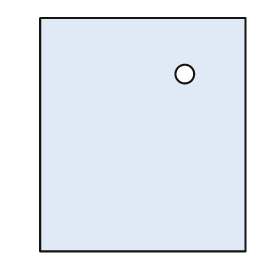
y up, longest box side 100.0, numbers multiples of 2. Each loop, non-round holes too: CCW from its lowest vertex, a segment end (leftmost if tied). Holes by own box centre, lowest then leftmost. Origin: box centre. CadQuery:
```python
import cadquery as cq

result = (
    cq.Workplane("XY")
    .moveTo(-44.0, -50.0)
    .lineTo(44.0, -50.0)
    .lineTo(44.0, 50.0)
    .lineTo(-44.0, 50.0)
    .close()
    .moveTo(18.0, 26.0)
    .circle(4.0)
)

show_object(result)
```